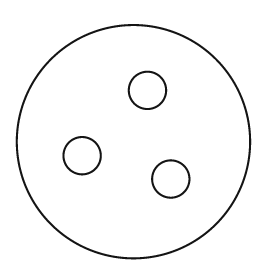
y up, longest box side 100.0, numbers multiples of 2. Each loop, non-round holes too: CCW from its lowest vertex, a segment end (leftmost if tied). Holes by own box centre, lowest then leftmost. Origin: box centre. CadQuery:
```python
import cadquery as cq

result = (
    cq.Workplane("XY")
    .moveTo(0.0, 0.0)
    .circle(50.0)
    .moveTo(16.0, -16.0)
    .circle(8.0)
    .moveTo(-22.0, -6.0)
    .circle(8.0)
    .moveTo(6.0, 22.0)
    .circle(8.0)
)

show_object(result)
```